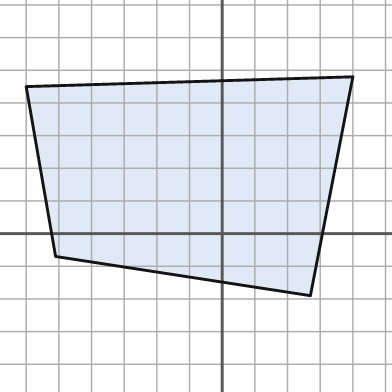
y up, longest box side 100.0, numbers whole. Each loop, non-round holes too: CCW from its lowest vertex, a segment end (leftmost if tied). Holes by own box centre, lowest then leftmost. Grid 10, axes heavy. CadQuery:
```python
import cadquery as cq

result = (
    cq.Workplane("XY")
    .moveTo(27.0, -19.0)
    .lineTo(40.0, 48.0)
    .lineTo(-60.0, 45.0)
    .lineTo(-51.0, -7.0)
    .close()
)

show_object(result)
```